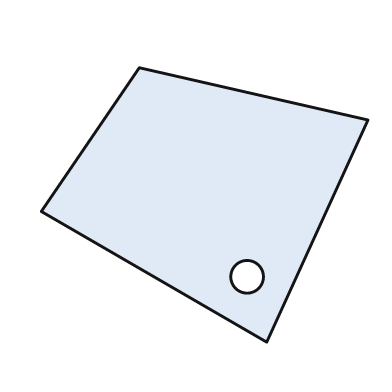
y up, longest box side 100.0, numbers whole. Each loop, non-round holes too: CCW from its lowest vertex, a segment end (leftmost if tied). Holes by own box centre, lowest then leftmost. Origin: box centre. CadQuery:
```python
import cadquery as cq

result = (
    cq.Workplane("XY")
    .moveTo(19.0, -42.0)
    .lineTo(50.0, 26.0)
    .lineTo(-20.0, 42.0)
    .lineTo(-50.0, -2.0)
    .close()
    .moveTo(13.0, -22.0)
    .circle(5.0)
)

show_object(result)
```